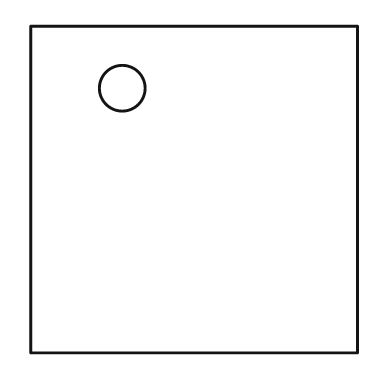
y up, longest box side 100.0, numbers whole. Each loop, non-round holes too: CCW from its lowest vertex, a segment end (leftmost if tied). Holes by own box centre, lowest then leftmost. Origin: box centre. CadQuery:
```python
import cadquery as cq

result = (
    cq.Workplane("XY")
    .moveTo(-50.0, -50.0)
    .lineTo(50.0, -50.0)
    .lineTo(50.0, 50.0)
    .lineTo(-50.0, 50.0)
    .close()
    .moveTo(-22.0, 31.0)
    .circle(7.0)
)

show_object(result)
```